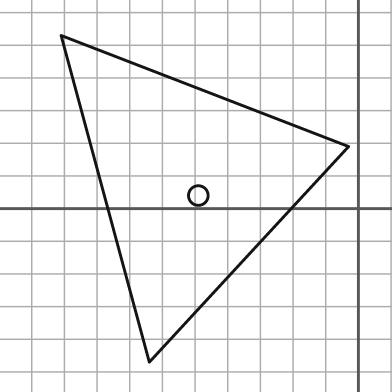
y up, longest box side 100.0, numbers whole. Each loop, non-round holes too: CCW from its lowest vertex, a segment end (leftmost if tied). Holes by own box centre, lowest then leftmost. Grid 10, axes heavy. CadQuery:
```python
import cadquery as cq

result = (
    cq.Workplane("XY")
    .moveTo(-64.0, -47.0)
    .lineTo(-3.0, 19.0)
    .lineTo(-91.0, 53.0)
    .close()
    .moveTo(-49.0, 4.0)
    .circle(3.0)
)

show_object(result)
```